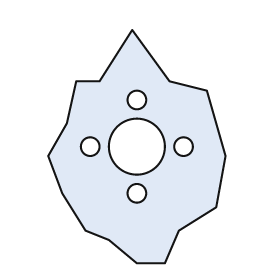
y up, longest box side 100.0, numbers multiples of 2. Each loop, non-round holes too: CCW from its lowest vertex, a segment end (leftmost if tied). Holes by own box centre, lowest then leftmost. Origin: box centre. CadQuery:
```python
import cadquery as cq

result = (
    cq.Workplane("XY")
    .moveTo(0.0, -50.0)
    .lineTo(12.0, -50.0)
    .lineTo(18.0, -36.0)
    .lineTo(34.0, -26.0)
    .lineTo(38.0, -4.0)
    .lineTo(30.0, 24.0)
    .lineTo(14.0, 28.0)
    .lineTo(-2.0, 50.0)
    .lineTo(-16.0, 28.0)
    .lineTo(-26.0, 28.0)
    .lineTo(-30.0, 10.0)
    .lineTo(-38.0, -4.0)
    .lineTo(-32.0, -20.0)
    .lineTo(-22.0, -36.0)
    .lineTo(-12.0, -40.0)
    .close()
    .moveTo(0.0, -20.0)
    .circle(4.0)
    .moveTo(-20.0, 0.0)
    .circle(4.0)
    .moveTo(0.0, 0.0)
    .circle(12.0)
    .moveTo(20.0, 0.0)
    .circle(4.0)
    .moveTo(0.0, 20.0)
    .circle(4.0)
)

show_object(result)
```